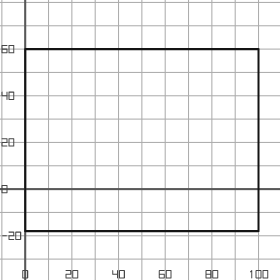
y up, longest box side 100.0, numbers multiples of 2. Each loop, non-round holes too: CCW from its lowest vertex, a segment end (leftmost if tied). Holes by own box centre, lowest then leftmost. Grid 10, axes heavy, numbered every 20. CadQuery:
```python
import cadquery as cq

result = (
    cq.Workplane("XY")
    .moveTo(0.0, -18.0)
    .lineTo(100.0, -18.0)
    .lineTo(100.0, 60.0)
    .lineTo(0.0, 60.0)
    .close()
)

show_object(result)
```